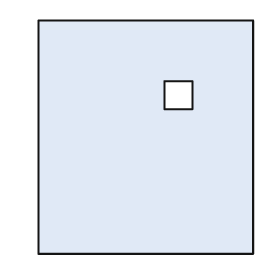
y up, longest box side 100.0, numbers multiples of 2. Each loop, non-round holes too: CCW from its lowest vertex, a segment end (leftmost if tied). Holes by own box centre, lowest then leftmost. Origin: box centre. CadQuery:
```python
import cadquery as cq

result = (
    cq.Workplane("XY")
    .moveTo(-46.0, -50.0)
    .lineTo(46.0, -50.0)
    .lineTo(46.0, 50.0)
    .lineTo(-46.0, 50.0)
    .close()
    .moveTo(8.0, 12.0)
    .lineTo(20.0, 12.0)
    .lineTo(20.0, 24.0)
    .lineTo(8.0, 24.0)
    .close()
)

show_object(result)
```